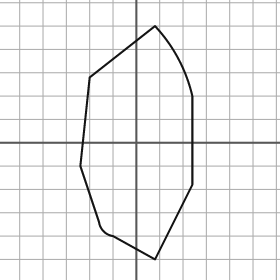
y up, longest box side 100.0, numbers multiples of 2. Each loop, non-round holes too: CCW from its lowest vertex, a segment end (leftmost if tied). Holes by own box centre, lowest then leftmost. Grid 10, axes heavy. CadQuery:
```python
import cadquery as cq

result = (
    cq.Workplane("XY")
    .moveTo(8.0, -50.0)
    .lineTo(24.0, -18.0)
    .lineTo(24.0, 20.0)
    .threePointArc((18.0, 36.0), (8.0, 50.0))
    .lineTo(-20.0, 28.0)
    .lineTo(-24.0, -10.0)
    .lineTo(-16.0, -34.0)
    .threePointArc((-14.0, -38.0), (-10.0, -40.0))
    .close()
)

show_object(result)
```